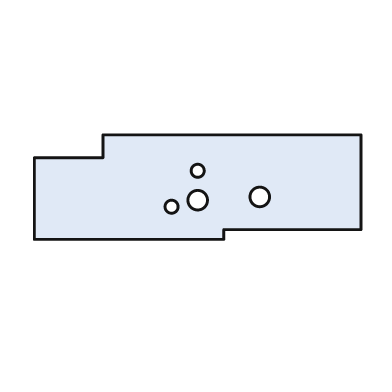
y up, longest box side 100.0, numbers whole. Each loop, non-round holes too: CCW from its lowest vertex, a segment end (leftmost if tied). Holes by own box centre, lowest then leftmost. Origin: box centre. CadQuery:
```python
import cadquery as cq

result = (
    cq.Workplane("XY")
    .moveTo(-50.0, -16.0)
    .lineTo(8.0, -16.0)
    .lineTo(8.0, -13.0)
    .lineTo(50.0, -13.0)
    .lineTo(50.0, 16.0)
    .lineTo(-29.0, 16.0)
    .lineTo(-29.0, 9.0)
    .lineTo(-50.0, 9.0)
    .close()
    .moveTo(-8.0, -6.0)
    .circle(2.0)
    .moveTo(0.0, -4.0)
    .circle(3.0)
    .moveTo(19.0, -3.0)
    .circle(3.0)
    .moveTo(0.0, 5.0)
    .circle(2.0)
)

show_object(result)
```